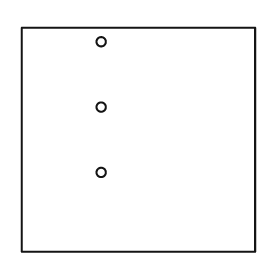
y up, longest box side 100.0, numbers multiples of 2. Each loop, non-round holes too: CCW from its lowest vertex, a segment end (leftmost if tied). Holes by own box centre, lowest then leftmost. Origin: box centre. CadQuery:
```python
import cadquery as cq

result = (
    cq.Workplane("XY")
    .moveTo(-50.0, -48.0)
    .lineTo(50.0, -48.0)
    .lineTo(50.0, 48.0)
    .lineTo(-50.0, 48.0)
    .close()
    .moveTo(-16.0, -14.0)
    .circle(2.0)
    .moveTo(-16.0, 14.0)
    .circle(2.0)
    .moveTo(-16.0, 42.0)
    .circle(2.0)
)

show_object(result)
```